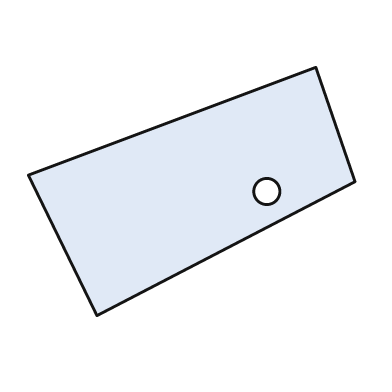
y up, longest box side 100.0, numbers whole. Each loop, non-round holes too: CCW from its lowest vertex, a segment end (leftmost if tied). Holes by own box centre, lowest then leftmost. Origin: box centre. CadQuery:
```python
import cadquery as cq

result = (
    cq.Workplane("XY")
    .moveTo(-29.0, -38.0)
    .lineTo(50.0, 3.0)
    .lineTo(38.0, 38.0)
    .lineTo(-50.0, 5.0)
    .close()
    .moveTo(23.0, 0.0)
    .circle(4.0)
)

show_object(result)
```